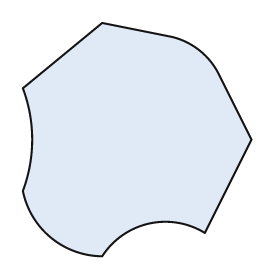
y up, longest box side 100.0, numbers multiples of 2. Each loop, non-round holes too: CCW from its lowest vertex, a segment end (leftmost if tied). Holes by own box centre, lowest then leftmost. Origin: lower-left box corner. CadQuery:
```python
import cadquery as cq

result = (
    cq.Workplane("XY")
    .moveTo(34.0, 0.0)
    .threePointArc((54.0, 14.0), (78.0, 10.0))
    .lineTo(98.0, 50.0)
    .lineTo(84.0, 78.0)
    .threePointArc((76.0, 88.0), (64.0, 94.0))
    .lineTo(34.0, 100.0)
    .lineTo(0.0, 72.0)
    .threePointArc((4.0, 50.0), (0.0, 28.0))
    .threePointArc((12.0, 8.0), (34.0, 0.0))
    .close()
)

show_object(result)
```